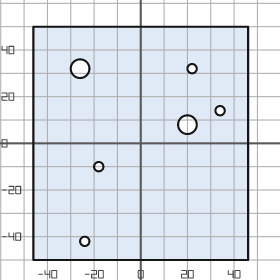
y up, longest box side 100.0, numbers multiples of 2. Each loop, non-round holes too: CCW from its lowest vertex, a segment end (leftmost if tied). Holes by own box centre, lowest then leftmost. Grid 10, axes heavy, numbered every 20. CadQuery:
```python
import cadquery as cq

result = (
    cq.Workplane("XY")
    .moveTo(-46.0, -50.0)
    .lineTo(46.0, -50.0)
    .lineTo(46.0, 50.0)
    .lineTo(-46.0, 50.0)
    .close()
    .moveTo(-24.0, -42.0)
    .circle(2.0)
    .moveTo(-18.0, -10.0)
    .circle(2.0)
    .moveTo(20.0, 8.0)
    .circle(4.0)
    .moveTo(34.0, 14.0)
    .circle(2.0)
    .moveTo(-26.0, 32.0)
    .circle(4.0)
    .moveTo(22.0, 32.0)
    .circle(2.0)
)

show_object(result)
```